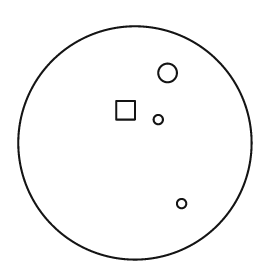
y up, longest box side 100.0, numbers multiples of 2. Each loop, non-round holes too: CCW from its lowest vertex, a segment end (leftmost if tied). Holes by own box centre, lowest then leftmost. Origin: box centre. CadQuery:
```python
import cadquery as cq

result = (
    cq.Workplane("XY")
    .moveTo(0.0, 0.0)
    .circle(50.0)
    .moveTo(20.0, -26.0)
    .circle(2.0)
    .moveTo(10.0, 10.0)
    .circle(2.0)
    .moveTo(-8.0, 10.0)
    .lineTo(0.0, 10.0)
    .lineTo(0.0, 18.0)
    .lineTo(-8.0, 18.0)
    .close()
    .moveTo(14.0, 30.0)
    .circle(4.0)
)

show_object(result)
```